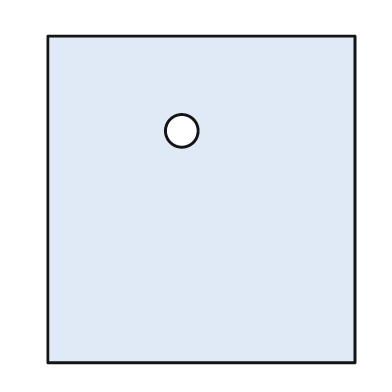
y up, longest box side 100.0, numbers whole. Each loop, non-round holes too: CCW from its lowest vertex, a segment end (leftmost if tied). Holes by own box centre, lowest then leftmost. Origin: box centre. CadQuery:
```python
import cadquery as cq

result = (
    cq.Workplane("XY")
    .moveTo(-47.0, -50.0)
    .lineTo(47.0, -50.0)
    .lineTo(47.0, 50.0)
    .lineTo(-47.0, 50.0)
    .close()
    .moveTo(-6.0, 21.0)
    .circle(5.0)
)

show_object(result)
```